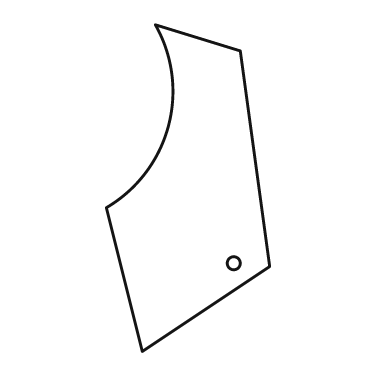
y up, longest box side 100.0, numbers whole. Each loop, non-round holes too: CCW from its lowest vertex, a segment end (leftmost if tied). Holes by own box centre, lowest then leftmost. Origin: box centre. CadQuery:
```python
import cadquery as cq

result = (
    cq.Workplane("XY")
    .moveTo(-14.0, -50.0)
    .lineTo(25.0, -24.0)
    .lineTo(16.0, 42.0)
    .lineTo(-10.0, 50.0)
    .threePointArc((-6.0, 19.0), (-25.0, -6.0))
    .close()
    .moveTo(14.0, -23.0)
    .circle(2.0)
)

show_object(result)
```